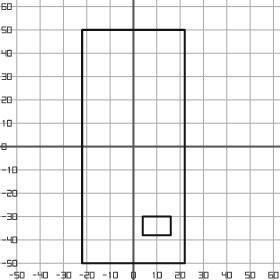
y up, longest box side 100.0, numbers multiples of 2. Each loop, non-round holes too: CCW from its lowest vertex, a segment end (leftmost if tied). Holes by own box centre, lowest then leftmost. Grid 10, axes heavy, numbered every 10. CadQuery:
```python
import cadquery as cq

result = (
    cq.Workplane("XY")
    .moveTo(-22.0, -50.0)
    .lineTo(22.0, -50.0)
    .lineTo(22.0, 50.0)
    .lineTo(-22.0, 50.0)
    .close()
    .moveTo(4.0, -38.0)
    .lineTo(16.0, -38.0)
    .lineTo(16.0, -30.0)
    .lineTo(4.0, -30.0)
    .close()
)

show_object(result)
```